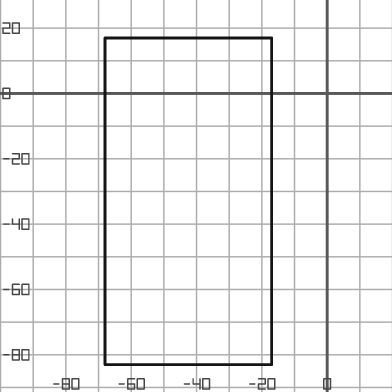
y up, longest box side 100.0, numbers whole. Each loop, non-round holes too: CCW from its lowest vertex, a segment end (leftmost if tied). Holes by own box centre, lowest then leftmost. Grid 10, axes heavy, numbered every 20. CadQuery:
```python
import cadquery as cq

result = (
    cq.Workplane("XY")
    .moveTo(-68.0, -83.0)
    .lineTo(-17.0, -83.0)
    .lineTo(-17.0, 17.0)
    .lineTo(-68.0, 17.0)
    .close()
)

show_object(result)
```